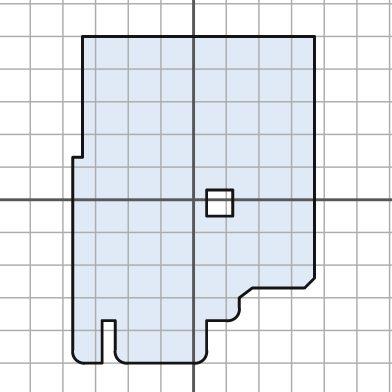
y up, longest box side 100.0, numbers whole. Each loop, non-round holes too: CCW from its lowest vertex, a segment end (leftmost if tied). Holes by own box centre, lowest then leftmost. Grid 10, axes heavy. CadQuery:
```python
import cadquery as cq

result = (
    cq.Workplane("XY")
    .moveTo(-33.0, -50.0)
    .lineTo(-28.0, -50.0)
    .lineTo(-28.0, -37.0)
    .lineTo(-24.0, -37.0)
    .lineTo(-24.0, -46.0)
    .threePointArc((-23.0, -49.0), (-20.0, -50.0))
    .lineTo(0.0, -50.0)
    .threePointArc((3.0, -49.0), (4.0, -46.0))
    .lineTo(4.0, -37.0)
    .lineTo(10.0, -37.0)
    .threePointArc((13.0, -36.0), (14.0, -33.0))
    .lineTo(14.0, -30.0)
    .lineTo(18.0, -27.0)
    .lineTo(34.0, -27.0)
    .lineTo(37.0, -24.0)
    .lineTo(37.0, 50.0)
    .lineTo(-34.0, 50.0)
    .lineTo(-34.0, 13.0)
    .lineTo(-37.0, 13.0)
    .lineTo(-37.0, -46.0)
    .threePointArc((-36.0, -49.0), (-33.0, -50.0))
    .close()
    .moveTo(4.0, -5.0)
    .lineTo(12.0, -5.0)
    .lineTo(12.0, 3.0)
    .lineTo(4.0, 3.0)
    .close()
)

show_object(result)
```